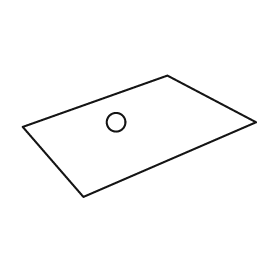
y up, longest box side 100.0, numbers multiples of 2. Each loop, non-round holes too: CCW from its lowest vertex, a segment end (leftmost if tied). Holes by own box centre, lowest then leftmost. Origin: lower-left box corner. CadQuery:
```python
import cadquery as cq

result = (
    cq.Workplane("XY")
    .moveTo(26.0, 0.0)
    .lineTo(100.0, 32.0)
    .lineTo(62.0, 52.0)
    .lineTo(0.0, 30.0)
    .close()
    .moveTo(40.0, 32.0)
    .circle(4.0)
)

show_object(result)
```